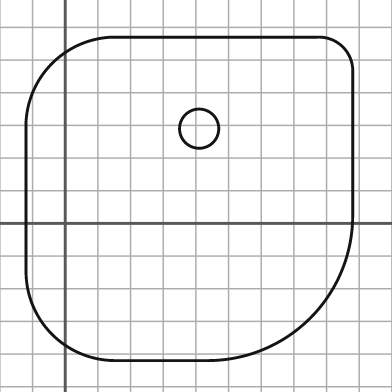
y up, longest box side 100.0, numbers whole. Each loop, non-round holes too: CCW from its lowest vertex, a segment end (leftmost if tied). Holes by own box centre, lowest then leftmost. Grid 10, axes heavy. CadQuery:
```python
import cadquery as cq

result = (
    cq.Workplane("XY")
    .moveTo(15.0, -42.0)
    .lineTo(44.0, -42.0)
    .threePointArc((75.0, -29.0), (88.0, 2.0))
    .lineTo(88.0, 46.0)
    .threePointArc((85.0, 54.0), (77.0, 57.0))
    .lineTo(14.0, 57.0)
    .threePointArc((-4.0, 49.0), (-12.0, 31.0))
    .lineTo(-12.0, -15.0)
    .threePointArc((-4.0, -34.0), (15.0, -42.0))
    .close()
    .moveTo(41.0, 29.0)
    .circle(6.0)
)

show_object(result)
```